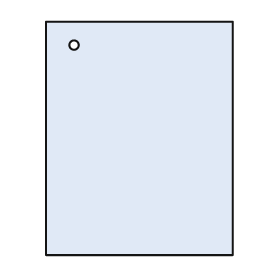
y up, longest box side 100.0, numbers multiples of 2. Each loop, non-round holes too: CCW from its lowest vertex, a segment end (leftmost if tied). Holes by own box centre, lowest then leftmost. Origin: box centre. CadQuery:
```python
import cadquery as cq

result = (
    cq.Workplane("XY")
    .moveTo(-40.0, -50.0)
    .lineTo(40.0, -50.0)
    .lineTo(40.0, 50.0)
    .lineTo(-40.0, 50.0)
    .close()
    .moveTo(-28.0, 40.0)
    .circle(2.0)
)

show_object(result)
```